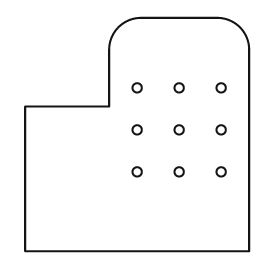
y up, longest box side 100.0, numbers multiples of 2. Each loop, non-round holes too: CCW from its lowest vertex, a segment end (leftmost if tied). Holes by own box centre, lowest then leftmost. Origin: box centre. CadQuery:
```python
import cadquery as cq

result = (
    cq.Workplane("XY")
    .moveTo(-48.0, -50.0)
    .lineTo(48.0, -50.0)
    .lineTo(48.0, 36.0)
    .threePointArc((44.0, 46.0), (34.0, 50.0))
    .lineTo(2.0, 50.0)
    .threePointArc((-8.0, 46.0), (-12.0, 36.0))
    .lineTo(-12.0, 12.0)
    .lineTo(-48.0, 12.0)
    .close()
    .moveTo(0.0, -16.0)
    .circle(2.0)
    .moveTo(18.0, -16.0)
    .circle(2.0)
    .moveTo(36.0, -16.0)
    .circle(2.0)
    .moveTo(0.0, 2.0)
    .circle(2.0)
    .moveTo(18.0, 2.0)
    .circle(2.0)
    .moveTo(36.0, 2.0)
    .circle(2.0)
    .moveTo(0.0, 20.0)
    .circle(2.0)
    .moveTo(18.0, 20.0)
    .circle(2.0)
    .moveTo(36.0, 20.0)
    .circle(2.0)
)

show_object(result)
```